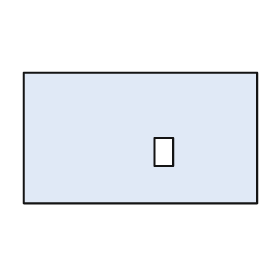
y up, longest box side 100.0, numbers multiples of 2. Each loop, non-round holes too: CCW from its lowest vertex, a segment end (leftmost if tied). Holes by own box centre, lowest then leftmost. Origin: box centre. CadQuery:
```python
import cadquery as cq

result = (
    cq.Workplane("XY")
    .moveTo(-50.0, -28.0)
    .lineTo(50.0, -28.0)
    .lineTo(50.0, 28.0)
    .lineTo(-50.0, 28.0)
    .close()
    .moveTo(6.0, -12.0)
    .lineTo(14.0, -12.0)
    .lineTo(14.0, 0.0)
    .lineTo(6.0, 0.0)
    .close()
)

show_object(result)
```